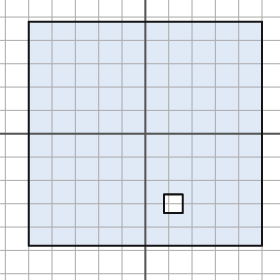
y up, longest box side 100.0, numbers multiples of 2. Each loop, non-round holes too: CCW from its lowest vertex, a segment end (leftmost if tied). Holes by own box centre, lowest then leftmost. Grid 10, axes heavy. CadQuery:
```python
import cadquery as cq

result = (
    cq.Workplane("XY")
    .moveTo(-50.0, -48.0)
    .lineTo(50.0, -48.0)
    .lineTo(50.0, 48.0)
    .lineTo(-50.0, 48.0)
    .close()
    .moveTo(8.0, -34.0)
    .lineTo(16.0, -34.0)
    .lineTo(16.0, -26.0)
    .lineTo(8.0, -26.0)
    .close()
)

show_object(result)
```